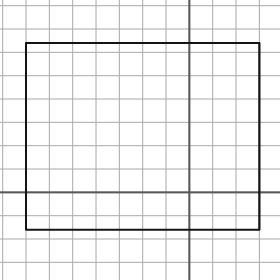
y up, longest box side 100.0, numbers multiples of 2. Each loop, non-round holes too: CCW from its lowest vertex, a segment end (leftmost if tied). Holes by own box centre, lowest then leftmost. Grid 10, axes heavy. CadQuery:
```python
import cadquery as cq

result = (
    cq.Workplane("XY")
    .moveTo(-70.0, -16.0)
    .lineTo(30.0, -16.0)
    .lineTo(30.0, 64.0)
    .lineTo(-70.0, 64.0)
    .close()
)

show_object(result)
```